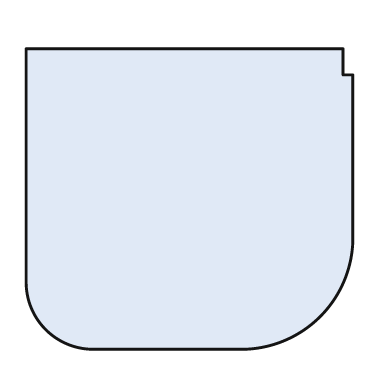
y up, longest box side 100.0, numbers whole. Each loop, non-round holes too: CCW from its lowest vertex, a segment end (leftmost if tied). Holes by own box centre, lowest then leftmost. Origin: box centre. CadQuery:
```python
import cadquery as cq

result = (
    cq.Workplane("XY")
    .moveTo(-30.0, -46.0)
    .lineTo(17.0, -46.0)
    .threePointArc((40.0, -36.0), (50.0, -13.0))
    .lineTo(50.0, 38.0)
    .lineTo(47.0, 38.0)
    .lineTo(47.0, 46.0)
    .lineTo(-50.0, 46.0)
    .lineTo(-50.0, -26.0)
    .threePointArc((-44.0, -40.0), (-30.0, -46.0))
    .close()
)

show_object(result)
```